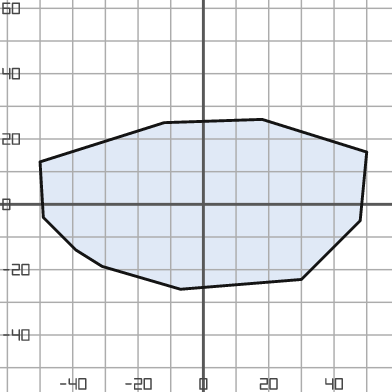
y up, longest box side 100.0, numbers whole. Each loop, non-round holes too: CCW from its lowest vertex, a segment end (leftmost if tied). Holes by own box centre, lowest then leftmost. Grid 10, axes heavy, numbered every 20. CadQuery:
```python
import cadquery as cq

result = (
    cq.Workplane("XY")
    .moveTo(-7.0, -26.0)
    .lineTo(30.0, -23.0)
    .lineTo(48.0, -5.0)
    .lineTo(50.0, 16.0)
    .lineTo(18.0, 26.0)
    .lineTo(-12.0, 25.0)
    .lineTo(-50.0, 13.0)
    .lineTo(-49.0, -4.0)
    .lineTo(-39.0, -14.0)
    .lineTo(-31.0, -19.0)
    .close()
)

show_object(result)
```